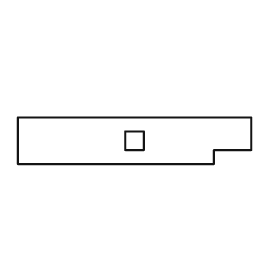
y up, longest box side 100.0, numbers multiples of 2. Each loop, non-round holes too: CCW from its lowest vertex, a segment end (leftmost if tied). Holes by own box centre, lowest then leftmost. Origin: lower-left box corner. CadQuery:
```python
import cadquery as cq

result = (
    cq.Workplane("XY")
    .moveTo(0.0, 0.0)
    .lineTo(84.0, 0.0)
    .lineTo(84.0, 6.0)
    .lineTo(100.0, 6.0)
    .lineTo(100.0, 20.0)
    .lineTo(0.0, 20.0)
    .close()
    .moveTo(46.0, 6.0)
    .lineTo(54.0, 6.0)
    .lineTo(54.0, 14.0)
    .lineTo(46.0, 14.0)
    .close()
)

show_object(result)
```